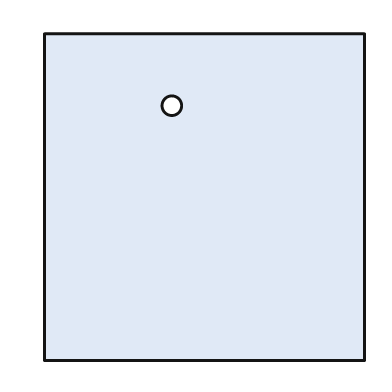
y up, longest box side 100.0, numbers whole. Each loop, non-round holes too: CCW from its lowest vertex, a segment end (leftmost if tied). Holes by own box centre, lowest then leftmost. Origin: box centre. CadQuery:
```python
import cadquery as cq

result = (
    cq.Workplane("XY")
    .moveTo(-49.0, -50.0)
    .lineTo(49.0, -50.0)
    .lineTo(49.0, 50.0)
    .lineTo(-49.0, 50.0)
    .close()
    .moveTo(-10.0, 28.0)
    .circle(3.0)
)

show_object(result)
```